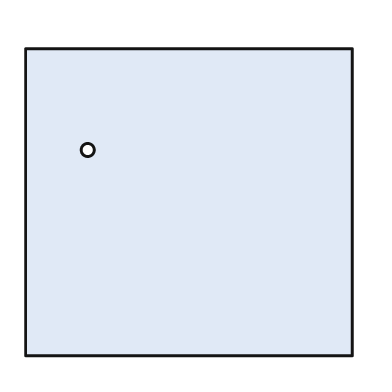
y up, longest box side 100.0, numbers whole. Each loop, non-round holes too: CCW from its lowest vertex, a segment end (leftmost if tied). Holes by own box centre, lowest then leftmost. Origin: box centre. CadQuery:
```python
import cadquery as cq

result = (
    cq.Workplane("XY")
    .moveTo(-50.0, -47.0)
    .lineTo(50.0, -47.0)
    .lineTo(50.0, 47.0)
    .lineTo(-50.0, 47.0)
    .close()
    .moveTo(-31.0, 16.0)
    .circle(2.0)
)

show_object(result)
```